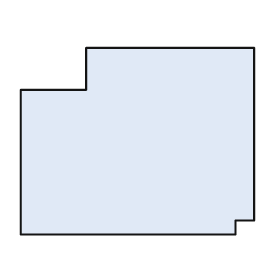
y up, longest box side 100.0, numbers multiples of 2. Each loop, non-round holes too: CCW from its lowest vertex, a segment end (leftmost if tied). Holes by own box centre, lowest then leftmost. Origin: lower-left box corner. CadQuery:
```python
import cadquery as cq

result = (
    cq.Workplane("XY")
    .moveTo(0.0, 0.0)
    .lineTo(92.0, 0.0)
    .lineTo(92.0, 6.0)
    .lineTo(100.0, 6.0)
    .lineTo(100.0, 80.0)
    .lineTo(28.0, 80.0)
    .lineTo(28.0, 62.0)
    .lineTo(0.0, 62.0)
    .close()
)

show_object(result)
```